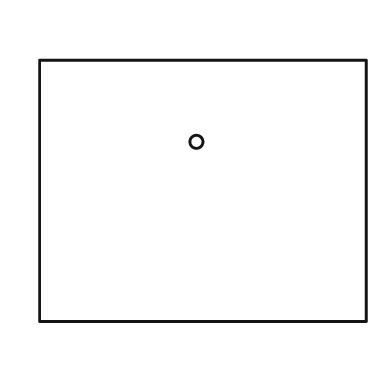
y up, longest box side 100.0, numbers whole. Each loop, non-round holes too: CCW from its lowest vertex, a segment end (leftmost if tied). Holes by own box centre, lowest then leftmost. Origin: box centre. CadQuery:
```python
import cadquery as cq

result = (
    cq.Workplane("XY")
    .moveTo(-50.0, -40.0)
    .lineTo(50.0, -40.0)
    .lineTo(50.0, 40.0)
    .lineTo(-50.0, 40.0)
    .close()
    .moveTo(-2.0, 15.0)
    .circle(2.0)
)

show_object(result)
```